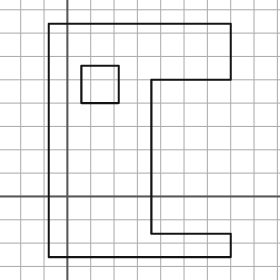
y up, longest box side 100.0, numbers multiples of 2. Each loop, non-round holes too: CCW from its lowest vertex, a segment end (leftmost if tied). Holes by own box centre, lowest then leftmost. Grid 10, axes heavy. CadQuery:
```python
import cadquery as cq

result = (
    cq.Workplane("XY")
    .moveTo(-8.0, -26.0)
    .lineTo(70.0, -26.0)
    .lineTo(70.0, -16.0)
    .lineTo(36.0, -16.0)
    .lineTo(36.0, 50.0)
    .lineTo(70.0, 50.0)
    .lineTo(70.0, 74.0)
    .lineTo(-8.0, 74.0)
    .close()
    .moveTo(6.0, 40.0)
    .lineTo(22.0, 40.0)
    .lineTo(22.0, 56.0)
    .lineTo(6.0, 56.0)
    .close()
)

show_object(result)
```